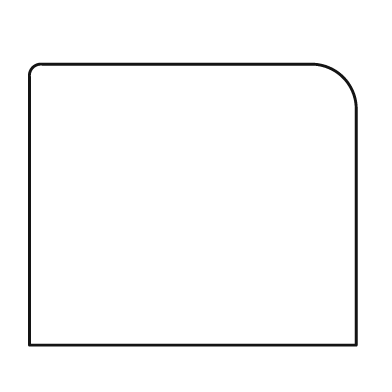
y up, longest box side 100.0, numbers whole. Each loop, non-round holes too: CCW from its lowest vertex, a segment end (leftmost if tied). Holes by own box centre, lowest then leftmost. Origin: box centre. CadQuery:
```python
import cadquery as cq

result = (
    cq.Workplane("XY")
    .moveTo(-50.0, -43.0)
    .lineTo(50.0, -43.0)
    .lineTo(50.0, 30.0)
    .threePointArc((46.0, 39.0), (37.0, 43.0))
    .lineTo(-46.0, 43.0)
    .threePointArc((-49.0, 42.0), (-50.0, 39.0))
    .close()
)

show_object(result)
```